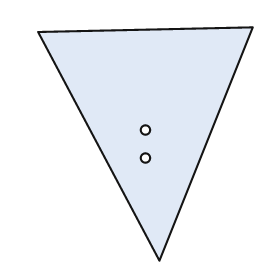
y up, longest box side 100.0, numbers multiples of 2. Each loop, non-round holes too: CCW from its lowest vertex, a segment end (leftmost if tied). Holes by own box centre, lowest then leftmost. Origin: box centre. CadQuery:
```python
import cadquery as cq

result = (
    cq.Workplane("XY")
    .moveTo(6.0, -50.0)
    .lineTo(46.0, 50.0)
    .lineTo(-46.0, 48.0)
    .close()
    .moveTo(0.0, -6.0)
    .circle(2.0)
    .moveTo(0.0, 6.0)
    .circle(2.0)
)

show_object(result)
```